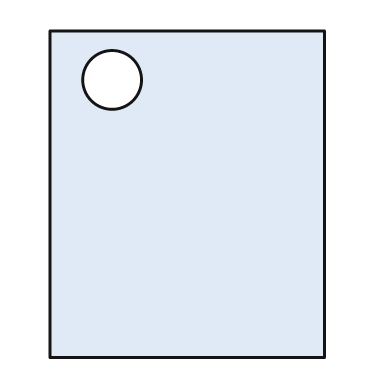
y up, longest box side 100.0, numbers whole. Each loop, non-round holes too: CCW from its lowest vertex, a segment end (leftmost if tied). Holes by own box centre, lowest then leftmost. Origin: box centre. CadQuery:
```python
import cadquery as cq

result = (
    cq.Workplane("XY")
    .moveTo(-42.0, -50.0)
    .lineTo(42.0, -50.0)
    .lineTo(42.0, 50.0)
    .lineTo(-42.0, 50.0)
    .close()
    .moveTo(-23.0, 35.0)
    .circle(9.0)
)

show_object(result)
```